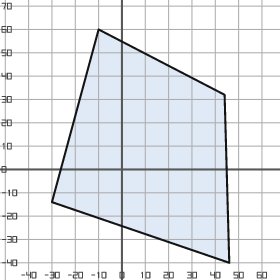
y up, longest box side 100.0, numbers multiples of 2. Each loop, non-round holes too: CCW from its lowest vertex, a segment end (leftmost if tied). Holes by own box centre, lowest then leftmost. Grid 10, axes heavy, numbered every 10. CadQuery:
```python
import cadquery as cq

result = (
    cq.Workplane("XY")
    .moveTo(46.0, -40.0)
    .lineTo(44.0, 32.0)
    .lineTo(-10.0, 60.0)
    .lineTo(-30.0, -14.0)
    .close()
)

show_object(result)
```